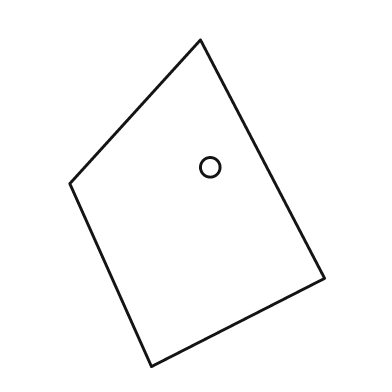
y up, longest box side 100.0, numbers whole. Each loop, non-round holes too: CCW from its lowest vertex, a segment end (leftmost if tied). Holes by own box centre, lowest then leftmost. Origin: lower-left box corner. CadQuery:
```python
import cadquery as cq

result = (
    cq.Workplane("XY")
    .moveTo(25.0, 0.0)
    .lineTo(78.0, 27.0)
    .lineTo(40.0, 100.0)
    .lineTo(0.0, 56.0)
    .close()
    .moveTo(43.0, 61.0)
    .circle(3.0)
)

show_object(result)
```